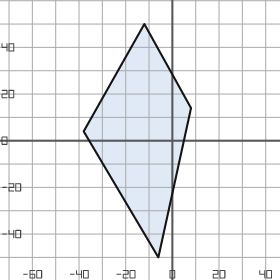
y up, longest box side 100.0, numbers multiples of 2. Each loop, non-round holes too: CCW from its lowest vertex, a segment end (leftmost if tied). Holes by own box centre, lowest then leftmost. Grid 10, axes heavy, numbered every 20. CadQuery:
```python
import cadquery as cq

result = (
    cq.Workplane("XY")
    .moveTo(-6.0, -50.0)
    .lineTo(8.0, 14.0)
    .lineTo(-12.0, 50.0)
    .lineTo(-38.0, 4.0)
    .close()
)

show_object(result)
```